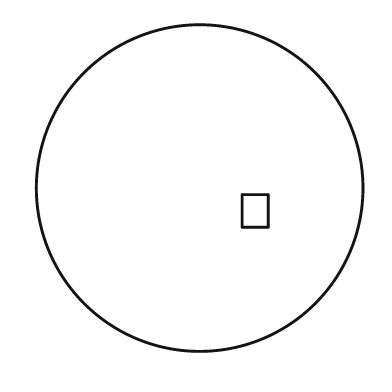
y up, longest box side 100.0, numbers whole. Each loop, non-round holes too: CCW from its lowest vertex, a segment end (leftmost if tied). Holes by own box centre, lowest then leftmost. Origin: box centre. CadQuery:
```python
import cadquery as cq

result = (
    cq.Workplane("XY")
    .moveTo(0.0, 0.0)
    .circle(50.0)
    .moveTo(13.0, -12.0)
    .lineTo(21.0, -12.0)
    .lineTo(21.0, -2.0)
    .lineTo(13.0, -2.0)
    .close()
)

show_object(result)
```